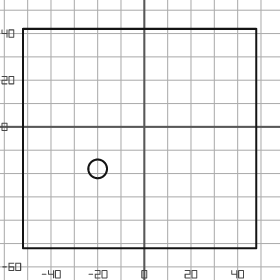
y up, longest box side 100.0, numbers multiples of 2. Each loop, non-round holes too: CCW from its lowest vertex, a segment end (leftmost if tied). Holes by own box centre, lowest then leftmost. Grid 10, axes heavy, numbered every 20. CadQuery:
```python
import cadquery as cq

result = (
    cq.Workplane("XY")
    .moveTo(-52.0, -52.0)
    .lineTo(48.0, -52.0)
    .lineTo(48.0, 42.0)
    .lineTo(-52.0, 42.0)
    .close()
    .moveTo(-20.0, -18.0)
    .circle(4.0)
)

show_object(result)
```